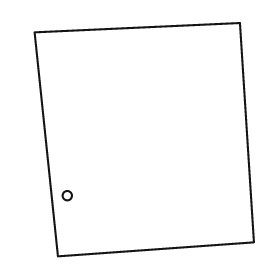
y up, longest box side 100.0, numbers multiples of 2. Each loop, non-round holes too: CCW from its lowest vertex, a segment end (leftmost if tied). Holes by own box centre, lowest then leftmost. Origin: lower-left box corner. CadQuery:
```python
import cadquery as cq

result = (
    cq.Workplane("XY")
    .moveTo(10.0, 0.0)
    .lineTo(94.0, 6.0)
    .lineTo(88.0, 100.0)
    .lineTo(0.0, 96.0)
    .close()
    .moveTo(14.0, 26.0)
    .circle(2.0)
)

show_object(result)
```